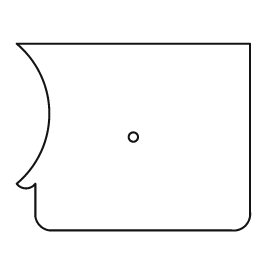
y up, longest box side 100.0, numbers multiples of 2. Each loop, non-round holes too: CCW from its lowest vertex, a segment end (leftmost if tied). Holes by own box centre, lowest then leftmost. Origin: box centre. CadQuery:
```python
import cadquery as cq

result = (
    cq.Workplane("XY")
    .moveTo(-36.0, -40.0)
    .lineTo(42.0, -40.0)
    .threePointArc((48.0, -38.0), (50.0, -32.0))
    .lineTo(50.0, 40.0)
    .lineTo(-50.0, 40.0)
    .threePointArc((-36.0, 10.0), (-50.0, -20.0))
    .threePointArc((-46.0, -22.0), (-42.0, -20.0))
    .lineTo(-42.0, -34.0)
    .threePointArc((-40.0, -38.0), (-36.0, -40.0))
    .close()
    .moveTo(0.0, 0.0)
    .circle(2.0)
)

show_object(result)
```